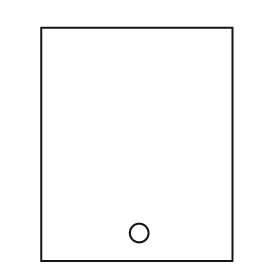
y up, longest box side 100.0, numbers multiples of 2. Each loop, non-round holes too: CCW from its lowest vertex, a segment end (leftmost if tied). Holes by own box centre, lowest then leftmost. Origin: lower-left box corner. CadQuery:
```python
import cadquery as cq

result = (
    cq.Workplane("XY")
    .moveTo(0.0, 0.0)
    .lineTo(82.0, 0.0)
    .lineTo(82.0, 100.0)
    .lineTo(0.0, 100.0)
    .close()
    .moveTo(42.0, 12.0)
    .circle(4.0)
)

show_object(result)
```